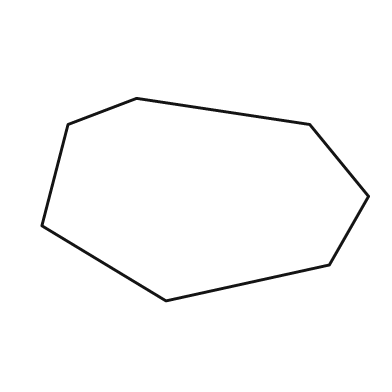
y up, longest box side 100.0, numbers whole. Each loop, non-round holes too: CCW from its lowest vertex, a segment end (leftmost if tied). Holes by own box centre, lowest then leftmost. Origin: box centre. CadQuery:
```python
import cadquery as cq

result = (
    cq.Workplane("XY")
    .moveTo(-12.0, -31.0)
    .lineTo(38.0, -20.0)
    .lineTo(50.0, 1.0)
    .lineTo(32.0, 23.0)
    .lineTo(-21.0, 31.0)
    .lineTo(-42.0, 23.0)
    .lineTo(-50.0, -8.0)
    .close()
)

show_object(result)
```